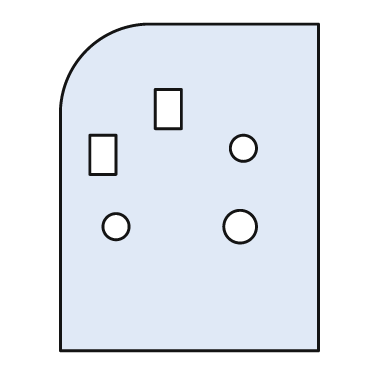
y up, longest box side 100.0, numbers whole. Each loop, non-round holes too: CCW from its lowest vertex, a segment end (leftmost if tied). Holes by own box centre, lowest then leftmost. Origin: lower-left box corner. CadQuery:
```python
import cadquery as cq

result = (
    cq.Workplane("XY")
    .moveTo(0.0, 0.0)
    .lineTo(79.0, 0.0)
    .lineTo(79.0, 100.0)
    .lineTo(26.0, 100.0)
    .threePointArc((8.0, 92.0), (0.0, 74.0))
    .close()
    .moveTo(17.0, 38.0)
    .circle(4.0)
    .moveTo(55.0, 38.0)
    .circle(5.0)
    .moveTo(9.0, 54.0)
    .lineTo(17.0, 54.0)
    .lineTo(17.0, 66.0)
    .lineTo(9.0, 66.0)
    .close()
    .moveTo(56.0, 62.0)
    .circle(4.0)
    .moveTo(29.0, 68.0)
    .lineTo(37.0, 68.0)
    .lineTo(37.0, 80.0)
    .lineTo(29.0, 80.0)
    .close()
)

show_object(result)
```